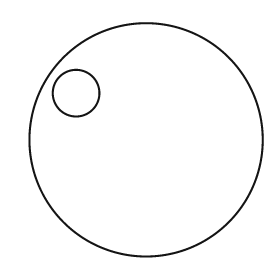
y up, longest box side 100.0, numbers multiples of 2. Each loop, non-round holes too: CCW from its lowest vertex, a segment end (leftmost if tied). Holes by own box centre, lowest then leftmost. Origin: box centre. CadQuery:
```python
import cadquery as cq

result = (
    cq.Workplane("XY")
    .moveTo(0.0, 0.0)
    .circle(50.0)
    .moveTo(-30.0, 20.0)
    .circle(10.0)
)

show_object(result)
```